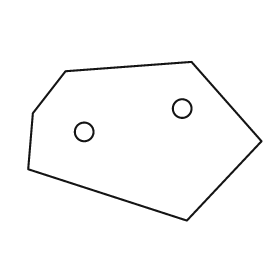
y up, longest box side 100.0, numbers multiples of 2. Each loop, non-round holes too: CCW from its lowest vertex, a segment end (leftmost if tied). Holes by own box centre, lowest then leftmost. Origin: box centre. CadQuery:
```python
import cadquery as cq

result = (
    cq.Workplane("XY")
    .moveTo(18.0, -34.0)
    .lineTo(50.0, 0.0)
    .lineTo(20.0, 34.0)
    .lineTo(-34.0, 30.0)
    .lineTo(-48.0, 12.0)
    .lineTo(-50.0, -12.0)
    .close()
    .moveTo(-26.0, 4.0)
    .circle(4.0)
    .moveTo(16.0, 14.0)
    .circle(4.0)
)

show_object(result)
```